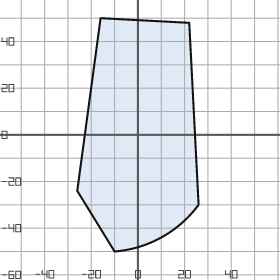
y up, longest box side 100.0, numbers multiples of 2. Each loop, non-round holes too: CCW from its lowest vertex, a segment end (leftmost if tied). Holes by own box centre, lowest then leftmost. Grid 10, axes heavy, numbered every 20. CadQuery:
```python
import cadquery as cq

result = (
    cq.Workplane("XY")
    .moveTo(-10.0, -50.0)
    .threePointArc((10.0, -44.0), (26.0, -30.0))
    .lineTo(22.0, 48.0)
    .lineTo(-16.0, 50.0)
    .lineTo(-26.0, -24.0)
    .close()
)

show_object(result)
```